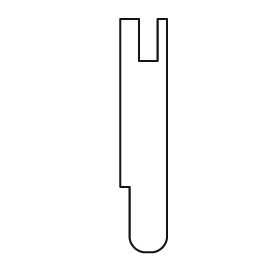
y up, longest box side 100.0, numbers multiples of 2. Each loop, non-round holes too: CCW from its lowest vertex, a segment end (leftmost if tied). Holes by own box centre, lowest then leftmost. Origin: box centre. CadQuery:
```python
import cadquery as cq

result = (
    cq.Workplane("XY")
    .moveTo(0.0, -50.0)
    .lineTo(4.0, -50.0)
    .threePointArc((8.0, -48.0), (10.0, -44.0))
    .lineTo(10.0, 50.0)
    .lineTo(6.0, 50.0)
    .lineTo(6.0, 32.0)
    .lineTo(-2.0, 32.0)
    .lineTo(-2.0, 50.0)
    .lineTo(-10.0, 50.0)
    .lineTo(-10.0, -22.0)
    .lineTo(-6.0, -22.0)
    .lineTo(-6.0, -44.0)
    .threePointArc((-4.0, -48.0), (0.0, -50.0))
    .close()
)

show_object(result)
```